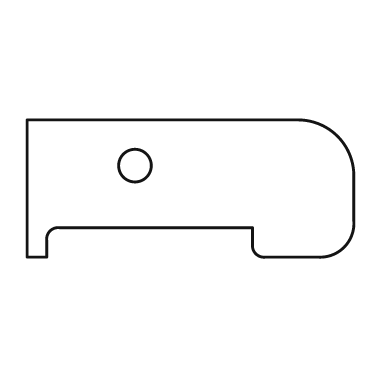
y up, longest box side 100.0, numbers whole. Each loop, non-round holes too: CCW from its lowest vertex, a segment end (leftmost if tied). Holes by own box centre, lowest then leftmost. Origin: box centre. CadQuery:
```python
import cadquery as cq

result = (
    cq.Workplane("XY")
    .moveTo(-50.0, -21.0)
    .lineTo(-44.0, -21.0)
    .lineTo(-44.0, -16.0)
    .threePointArc((-43.0, -13.0), (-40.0, -12.0))
    .lineTo(19.0, -12.0)
    .lineTo(19.0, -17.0)
    .threePointArc((20.0, -20.0), (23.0, -21.0))
    .lineTo(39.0, -21.0)
    .threePointArc((47.0, -18.0), (50.0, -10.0))
    .lineTo(50.0, 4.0)
    .threePointArc((45.0, 16.0), (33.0, 21.0))
    .lineTo(-50.0, 21.0)
    .close()
    .moveTo(-17.0, 7.0)
    .circle(5.0)
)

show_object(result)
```